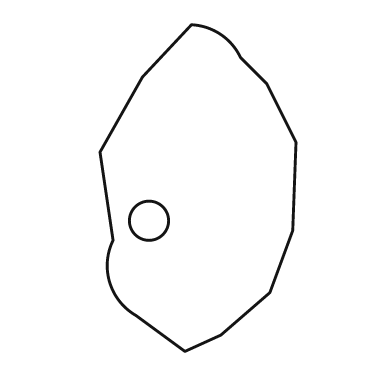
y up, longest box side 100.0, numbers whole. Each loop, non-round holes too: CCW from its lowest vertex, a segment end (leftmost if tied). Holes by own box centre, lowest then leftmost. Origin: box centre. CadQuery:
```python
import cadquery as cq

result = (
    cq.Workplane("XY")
    .moveTo(-4.0, -50.0)
    .lineTo(7.0, -45.0)
    .lineTo(22.0, -32.0)
    .lineTo(29.0, -13.0)
    .lineTo(30.0, 14.0)
    .lineTo(21.0, 32.0)
    .lineTo(13.0, 40.0)
    .threePointArc((7.0, 47.0), (-2.0, 50.0))
    .lineTo(-17.0, 34.0)
    .lineTo(-30.0, 11.0)
    .lineTo(-26.0, -16.0)
    .threePointArc((-27.0, -29.0), (-19.0, -39.0))
    .close()
    .moveTo(-15.0, -10.0)
    .circle(6.0)
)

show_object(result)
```